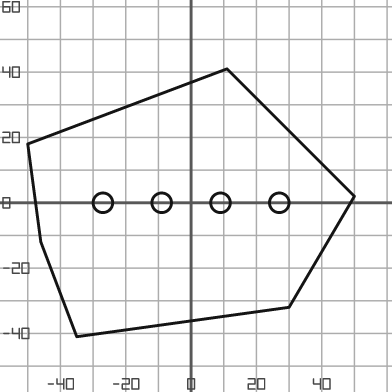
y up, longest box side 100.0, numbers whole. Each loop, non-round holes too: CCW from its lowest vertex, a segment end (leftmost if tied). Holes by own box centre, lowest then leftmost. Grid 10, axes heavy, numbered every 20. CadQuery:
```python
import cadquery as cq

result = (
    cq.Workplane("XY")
    .moveTo(-35.0, -41.0)
    .lineTo(30.0, -32.0)
    .lineTo(50.0, 2.0)
    .lineTo(11.0, 41.0)
    .lineTo(-50.0, 18.0)
    .lineTo(-46.0, -12.0)
    .close()
    .moveTo(-27.0, 0.0)
    .circle(3.0)
    .moveTo(-9.0, 0.0)
    .circle(3.0)
    .moveTo(9.0, 0.0)
    .circle(3.0)
    .moveTo(27.0, 0.0)
    .circle(3.0)
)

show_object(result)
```